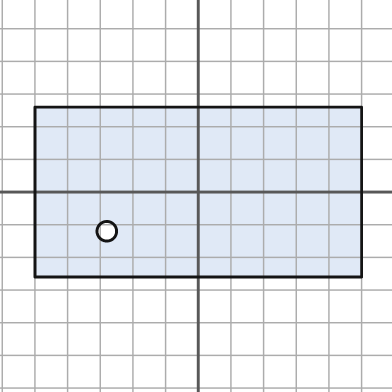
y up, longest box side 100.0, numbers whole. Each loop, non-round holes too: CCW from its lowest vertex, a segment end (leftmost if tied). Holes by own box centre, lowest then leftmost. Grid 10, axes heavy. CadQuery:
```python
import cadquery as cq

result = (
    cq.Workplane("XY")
    .moveTo(-50.0, -26.0)
    .lineTo(50.0, -26.0)
    .lineTo(50.0, 26.0)
    .lineTo(-50.0, 26.0)
    .close()
    .moveTo(-28.0, -12.0)
    .circle(3.0)
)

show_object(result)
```